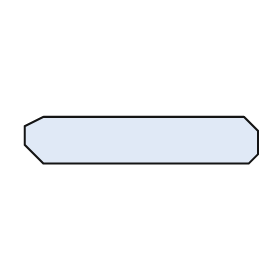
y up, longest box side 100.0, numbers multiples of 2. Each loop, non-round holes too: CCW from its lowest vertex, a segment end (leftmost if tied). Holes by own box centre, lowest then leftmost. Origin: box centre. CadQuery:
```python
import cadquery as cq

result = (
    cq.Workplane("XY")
    .moveTo(-42.0, -10.0)
    .lineTo(46.0, -10.0)
    .lineTo(50.0, -6.0)
    .lineTo(50.0, 4.0)
    .lineTo(44.0, 10.0)
    .lineTo(-42.0, 10.0)
    .lineTo(-50.0, 6.0)
    .lineTo(-50.0, -2.0)
    .close()
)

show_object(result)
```